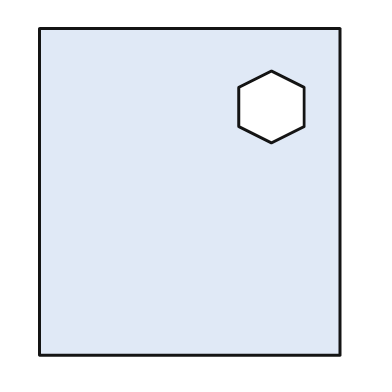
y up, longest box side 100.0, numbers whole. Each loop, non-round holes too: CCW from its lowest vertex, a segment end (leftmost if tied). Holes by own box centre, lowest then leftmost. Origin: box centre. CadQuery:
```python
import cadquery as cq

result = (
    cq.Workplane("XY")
    .moveTo(-46.0, -50.0)
    .lineTo(46.0, -50.0)
    .lineTo(46.0, 50.0)
    .lineTo(-46.0, 50.0)
    .close()
    .moveTo(25.0, 15.0)
    .lineTo(35.0, 20.0)
    .lineTo(35.0, 32.0)
    .lineTo(25.0, 37.0)
    .lineTo(15.0, 32.0)
    .lineTo(15.0, 20.0)
    .close()
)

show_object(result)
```